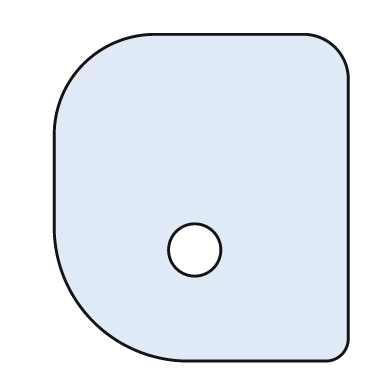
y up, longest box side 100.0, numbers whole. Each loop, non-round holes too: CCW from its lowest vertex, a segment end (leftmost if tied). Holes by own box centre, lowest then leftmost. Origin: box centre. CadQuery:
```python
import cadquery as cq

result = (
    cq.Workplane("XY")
    .moveTo(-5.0, -50.0)
    .lineTo(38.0, -50.0)
    .threePointArc((43.0, -48.0), (45.0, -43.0))
    .lineTo(45.0, 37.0)
    .threePointArc((41.0, 46.0), (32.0, 50.0))
    .lineTo(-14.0, 50.0)
    .threePointArc((-36.0, 41.0), (-45.0, 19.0))
    .lineTo(-45.0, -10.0)
    .threePointArc((-33.0, -38.0), (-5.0, -50.0))
    .close()
    .moveTo(-2.0, -16.0)
    .circle(8.0)
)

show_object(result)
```